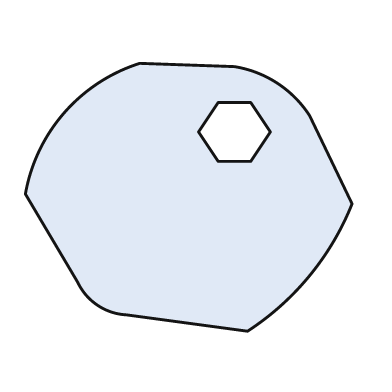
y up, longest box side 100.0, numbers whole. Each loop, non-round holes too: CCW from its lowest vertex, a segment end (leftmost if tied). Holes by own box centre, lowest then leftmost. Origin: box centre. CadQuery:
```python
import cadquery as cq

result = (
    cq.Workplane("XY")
    .moveTo(18.0, -41.0)
    .threePointArc((37.0, -24.0), (50.0, -2.0))
    .lineTo(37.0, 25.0)
    .threePointArc((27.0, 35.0), (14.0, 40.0))
    .lineTo(-15.0, 41.0)
    .threePointArc((-38.0, 26.0), (-50.0, 1.0))
    .lineTo(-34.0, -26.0)
    .threePointArc((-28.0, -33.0), (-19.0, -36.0))
    .close()
    .moveTo(9.0, 11.0)
    .lineTo(19.0, 11.0)
    .lineTo(25.0, 20.0)
    .lineTo(19.0, 29.0)
    .lineTo(9.0, 29.0)
    .lineTo(3.0, 20.0)
    .close()
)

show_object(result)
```